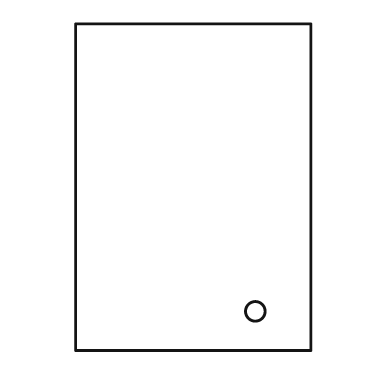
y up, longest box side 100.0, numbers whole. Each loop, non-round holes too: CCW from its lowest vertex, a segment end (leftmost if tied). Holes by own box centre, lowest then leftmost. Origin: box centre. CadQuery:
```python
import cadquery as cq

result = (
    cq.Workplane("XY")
    .moveTo(-36.0, -50.0)
    .lineTo(36.0, -50.0)
    .lineTo(36.0, 50.0)
    .lineTo(-36.0, 50.0)
    .close()
    .moveTo(19.0, -38.0)
    .circle(3.0)
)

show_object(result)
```